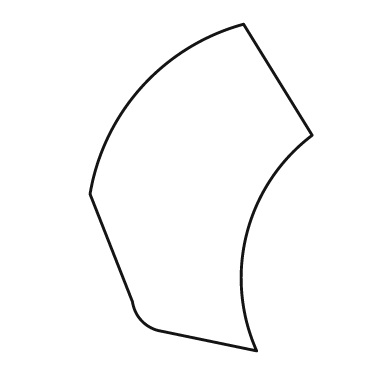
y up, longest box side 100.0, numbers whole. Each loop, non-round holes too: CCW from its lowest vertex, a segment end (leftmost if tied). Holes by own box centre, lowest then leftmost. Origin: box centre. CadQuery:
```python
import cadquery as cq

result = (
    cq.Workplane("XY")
    .moveTo(17.0, -50.0)
    .threePointArc((14.0, -14.0), (34.0, 16.0))
    .lineTo(13.0, 50.0)
    .threePointArc((-18.0, 31.0), (-34.0, -2.0))
    .lineTo(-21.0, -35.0)
    .threePointArc((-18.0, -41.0), (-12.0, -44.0))
    .close()
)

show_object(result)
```